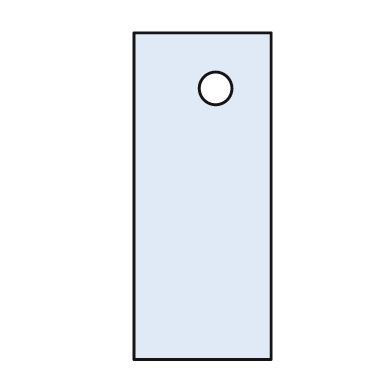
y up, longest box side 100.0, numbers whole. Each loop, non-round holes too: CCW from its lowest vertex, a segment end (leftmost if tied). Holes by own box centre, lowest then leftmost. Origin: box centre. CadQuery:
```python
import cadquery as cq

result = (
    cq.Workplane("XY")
    .moveTo(-21.0, -50.0)
    .lineTo(21.0, -50.0)
    .lineTo(21.0, 50.0)
    .lineTo(-21.0, 50.0)
    .close()
    .moveTo(4.0, 33.0)
    .circle(5.0)
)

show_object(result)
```